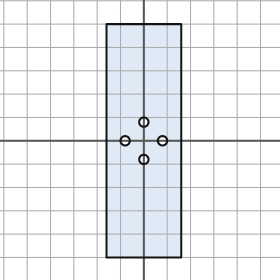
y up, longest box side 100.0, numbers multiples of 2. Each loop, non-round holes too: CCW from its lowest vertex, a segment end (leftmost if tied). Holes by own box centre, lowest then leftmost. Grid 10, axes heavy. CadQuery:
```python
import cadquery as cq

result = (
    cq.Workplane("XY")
    .moveTo(-16.0, -50.0)
    .lineTo(16.0, -50.0)
    .lineTo(16.0, 50.0)
    .lineTo(-16.0, 50.0)
    .close()
    .moveTo(0.0, -8.0)
    .circle(2.0)
    .moveTo(-8.0, 0.0)
    .circle(2.0)
    .moveTo(8.0, 0.0)
    .circle(2.0)
    .moveTo(0.0, 8.0)
    .circle(2.0)
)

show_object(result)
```